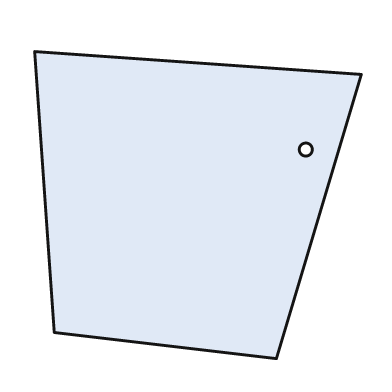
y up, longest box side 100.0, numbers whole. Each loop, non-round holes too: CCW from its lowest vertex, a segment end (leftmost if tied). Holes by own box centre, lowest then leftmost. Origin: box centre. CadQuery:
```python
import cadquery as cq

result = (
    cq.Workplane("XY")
    .moveTo(24.0, -47.0)
    .lineTo(50.0, 40.0)
    .lineTo(-50.0, 47.0)
    .lineTo(-44.0, -39.0)
    .close()
    .moveTo(33.0, 17.0)
    .circle(2.0)
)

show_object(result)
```